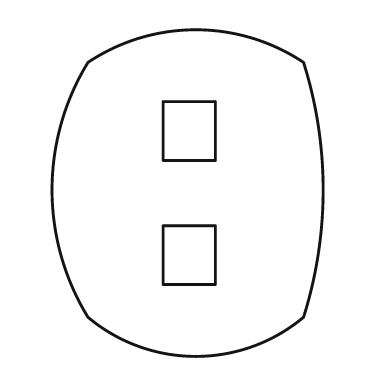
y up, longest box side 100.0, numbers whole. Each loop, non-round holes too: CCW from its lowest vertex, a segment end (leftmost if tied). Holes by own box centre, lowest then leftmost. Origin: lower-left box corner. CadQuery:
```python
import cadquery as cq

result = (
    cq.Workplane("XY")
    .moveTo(11.0, 12.0)
    .threePointArc((44.0, 0.0), (77.0, 12.0))
    .threePointArc((83.0, 51.0), (77.0, 90.0))
    .threePointArc((44.0, 100.0), (11.0, 90.0))
    .threePointArc((0.0, 51.0), (11.0, 12.0))
    .close()
    .moveTo(34.0, 22.0)
    .lineTo(50.0, 22.0)
    .lineTo(50.0, 40.0)
    .lineTo(34.0, 40.0)
    .close()
    .moveTo(34.0, 60.0)
    .lineTo(50.0, 60.0)
    .lineTo(50.0, 78.0)
    .lineTo(34.0, 78.0)
    .close()
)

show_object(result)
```